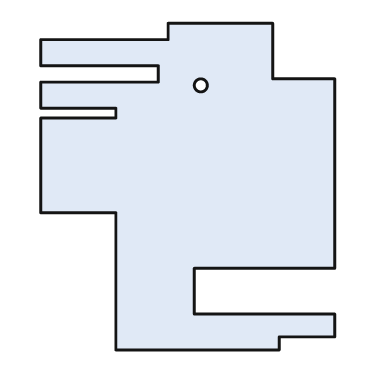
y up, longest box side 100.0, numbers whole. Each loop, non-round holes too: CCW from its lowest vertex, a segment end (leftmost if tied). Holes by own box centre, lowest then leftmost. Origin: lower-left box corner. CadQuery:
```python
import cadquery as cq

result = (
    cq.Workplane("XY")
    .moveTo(23.0, 0.0)
    .lineTo(73.0, 0.0)
    .lineTo(73.0, 4.0)
    .lineTo(90.0, 4.0)
    .lineTo(90.0, 11.0)
    .lineTo(47.0, 11.0)
    .lineTo(47.0, 25.0)
    .lineTo(90.0, 25.0)
    .lineTo(90.0, 83.0)
    .lineTo(71.0, 83.0)
    .lineTo(71.0, 100.0)
    .lineTo(39.0, 100.0)
    .lineTo(39.0, 95.0)
    .lineTo(0.0, 95.0)
    .lineTo(0.0, 87.0)
    .lineTo(36.0, 87.0)
    .lineTo(36.0, 82.0)
    .lineTo(0.0, 82.0)
    .lineTo(0.0, 74.0)
    .lineTo(23.0, 74.0)
    .lineTo(23.0, 71.0)
    .lineTo(0.0, 71.0)
    .lineTo(0.0, 42.0)
    .lineTo(23.0, 42.0)
    .close()
    .moveTo(49.0, 81.0)
    .circle(2.0)
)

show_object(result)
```